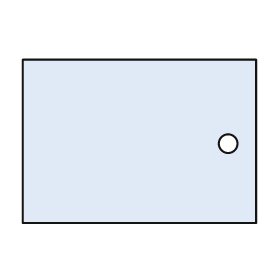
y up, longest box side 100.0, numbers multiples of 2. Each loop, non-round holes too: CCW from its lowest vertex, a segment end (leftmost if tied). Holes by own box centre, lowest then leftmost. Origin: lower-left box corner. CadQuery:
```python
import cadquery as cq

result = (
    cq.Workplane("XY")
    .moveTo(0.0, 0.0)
    .lineTo(100.0, 0.0)
    .lineTo(100.0, 70.0)
    .lineTo(0.0, 70.0)
    .close()
    .moveTo(88.0, 34.0)
    .circle(4.0)
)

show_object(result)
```